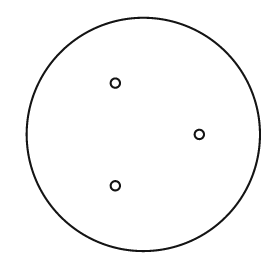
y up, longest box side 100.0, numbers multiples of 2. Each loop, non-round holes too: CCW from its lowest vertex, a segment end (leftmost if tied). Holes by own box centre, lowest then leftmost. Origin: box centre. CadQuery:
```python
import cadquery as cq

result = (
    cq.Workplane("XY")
    .moveTo(0.0, 0.0)
    .circle(50.0)
    .moveTo(-12.0, -22.0)
    .circle(2.0)
    .moveTo(24.0, 0.0)
    .circle(2.0)
    .moveTo(-12.0, 22.0)
    .circle(2.0)
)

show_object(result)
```